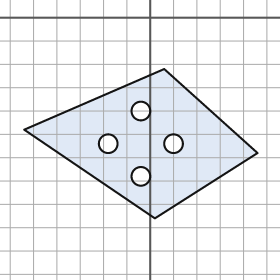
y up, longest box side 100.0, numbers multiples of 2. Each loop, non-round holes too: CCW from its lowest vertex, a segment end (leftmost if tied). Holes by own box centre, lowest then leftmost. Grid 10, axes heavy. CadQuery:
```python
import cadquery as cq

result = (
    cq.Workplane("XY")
    .moveTo(2.0, -86.0)
    .lineTo(46.0, -58.0)
    .lineTo(6.0, -22.0)
    .lineTo(-54.0, -48.0)
    .close()
    .moveTo(-4.0, -68.0)
    .circle(4.0)
    .moveTo(-18.0, -54.0)
    .circle(4.0)
    .moveTo(10.0, -54.0)
    .circle(4.0)
    .moveTo(-4.0, -40.0)
    .circle(4.0)
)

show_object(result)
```